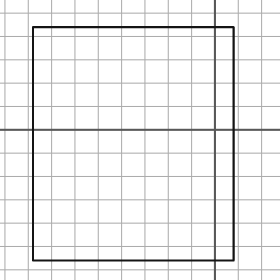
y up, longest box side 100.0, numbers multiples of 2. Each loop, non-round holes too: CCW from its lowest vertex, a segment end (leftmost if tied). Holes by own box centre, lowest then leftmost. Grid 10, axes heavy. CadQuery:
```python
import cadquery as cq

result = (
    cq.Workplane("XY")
    .moveTo(-78.0, -56.0)
    .lineTo(8.0, -56.0)
    .lineTo(8.0, 44.0)
    .lineTo(-78.0, 44.0)
    .close()
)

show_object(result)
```